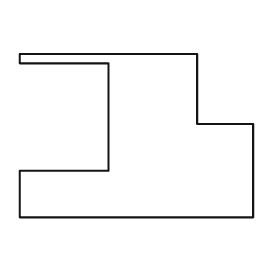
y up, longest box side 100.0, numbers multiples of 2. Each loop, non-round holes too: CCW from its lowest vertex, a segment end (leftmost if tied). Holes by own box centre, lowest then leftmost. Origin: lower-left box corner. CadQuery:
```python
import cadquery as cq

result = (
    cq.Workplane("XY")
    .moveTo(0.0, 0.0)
    .lineTo(100.0, 0.0)
    .lineTo(100.0, 40.0)
    .lineTo(76.0, 40.0)
    .lineTo(76.0, 70.0)
    .lineTo(0.0, 70.0)
    .lineTo(0.0, 66.0)
    .lineTo(38.0, 66.0)
    .lineTo(38.0, 20.0)
    .lineTo(0.0, 20.0)
    .close()
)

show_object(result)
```